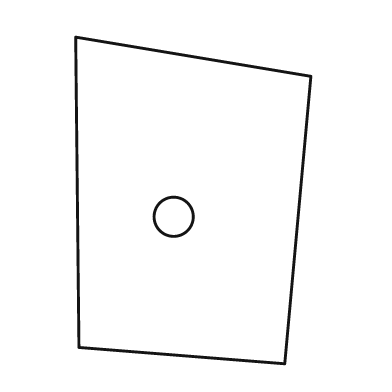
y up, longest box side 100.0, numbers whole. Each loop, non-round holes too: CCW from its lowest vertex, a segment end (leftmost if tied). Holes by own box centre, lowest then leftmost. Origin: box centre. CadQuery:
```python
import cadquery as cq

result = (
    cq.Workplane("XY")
    .moveTo(28.0, -50.0)
    .lineTo(36.0, 38.0)
    .lineTo(-36.0, 50.0)
    .lineTo(-35.0, -45.0)
    .close()
    .moveTo(-6.0, -5.0)
    .circle(6.0)
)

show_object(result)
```